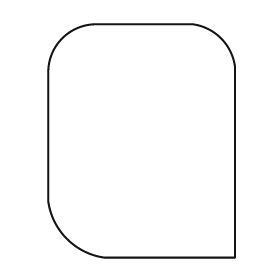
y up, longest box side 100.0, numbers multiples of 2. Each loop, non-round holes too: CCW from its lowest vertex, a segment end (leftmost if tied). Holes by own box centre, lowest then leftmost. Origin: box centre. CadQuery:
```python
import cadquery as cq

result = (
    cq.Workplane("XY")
    .moveTo(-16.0, -50.0)
    .lineTo(40.0, -50.0)
    .lineTo(40.0, 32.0)
    .threePointArc((34.0, 44.0), (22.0, 50.0))
    .lineTo(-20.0, 50.0)
    .threePointArc((-34.0, 44.0), (-40.0, 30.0))
    .lineTo(-40.0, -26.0)
    .threePointArc((-32.0, -42.0), (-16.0, -50.0))
    .close()
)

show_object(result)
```